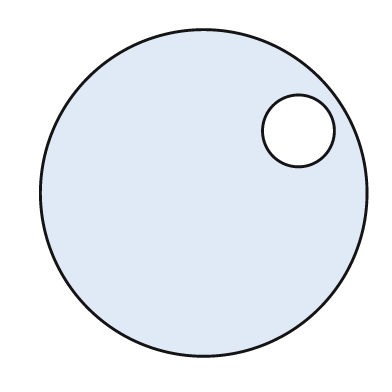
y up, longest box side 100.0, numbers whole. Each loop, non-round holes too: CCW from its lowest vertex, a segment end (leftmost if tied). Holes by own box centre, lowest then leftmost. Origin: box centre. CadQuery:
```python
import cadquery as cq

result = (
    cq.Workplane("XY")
    .moveTo(0.0, 0.0)
    .circle(50.0)
    .moveTo(29.0, 19.0)
    .circle(11.0)
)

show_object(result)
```